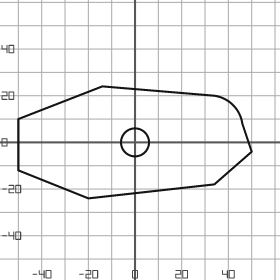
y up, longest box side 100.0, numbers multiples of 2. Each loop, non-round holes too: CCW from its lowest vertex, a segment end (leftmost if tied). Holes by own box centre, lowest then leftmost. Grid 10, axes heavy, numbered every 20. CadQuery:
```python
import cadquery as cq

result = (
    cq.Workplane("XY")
    .moveTo(-20.0, -24.0)
    .lineTo(34.0, -18.0)
    .lineTo(50.0, -4.0)
    .lineTo(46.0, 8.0)
    .threePointArc((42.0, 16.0), (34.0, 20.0))
    .lineTo(-14.0, 24.0)
    .lineTo(-50.0, 10.0)
    .lineTo(-50.0, -12.0)
    .close()
    .moveTo(0.0, 0.0)
    .circle(6.0)
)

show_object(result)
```